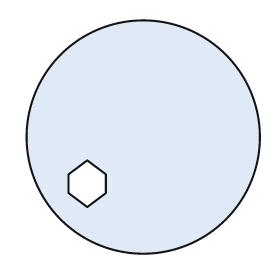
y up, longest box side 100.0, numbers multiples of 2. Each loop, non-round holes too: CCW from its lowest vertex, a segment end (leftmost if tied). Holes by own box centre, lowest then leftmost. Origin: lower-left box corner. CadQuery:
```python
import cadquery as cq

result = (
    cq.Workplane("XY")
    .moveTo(50.0, 50.0)
    .circle(50.0)
    .moveTo(26.0, 20.0)
    .lineTo(34.0, 26.0)
    .lineTo(34.0, 34.0)
    .lineTo(26.0, 40.0)
    .lineTo(18.0, 34.0)
    .lineTo(18.0, 26.0)
    .close()
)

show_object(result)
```